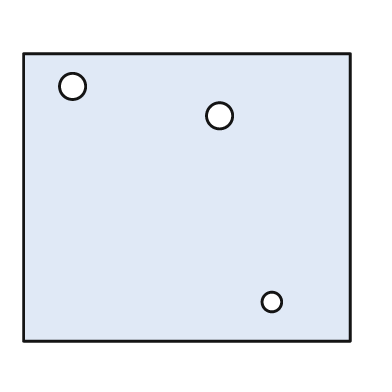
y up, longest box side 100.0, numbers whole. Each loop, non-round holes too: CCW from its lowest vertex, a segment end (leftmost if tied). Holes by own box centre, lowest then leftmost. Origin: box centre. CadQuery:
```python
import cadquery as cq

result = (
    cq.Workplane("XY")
    .moveTo(-50.0, -44.0)
    .lineTo(50.0, -44.0)
    .lineTo(50.0, 44.0)
    .lineTo(-50.0, 44.0)
    .close()
    .moveTo(26.0, -32.0)
    .circle(3.0)
    .moveTo(10.0, 25.0)
    .circle(4.0)
    .moveTo(-35.0, 34.0)
    .circle(4.0)
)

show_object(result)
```